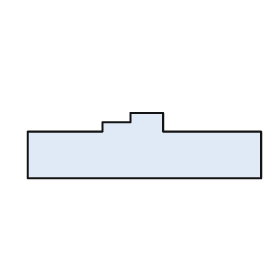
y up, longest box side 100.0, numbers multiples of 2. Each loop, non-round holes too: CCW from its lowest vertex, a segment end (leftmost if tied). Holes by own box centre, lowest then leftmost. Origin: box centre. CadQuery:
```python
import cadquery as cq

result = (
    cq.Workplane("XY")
    .moveTo(-50.0, -14.0)
    .lineTo(50.0, -14.0)
    .lineTo(50.0, 6.0)
    .lineTo(8.0, 6.0)
    .lineTo(8.0, 14.0)
    .lineTo(-6.0, 14.0)
    .lineTo(-6.0, 10.0)
    .lineTo(-18.0, 10.0)
    .lineTo(-18.0, 6.0)
    .lineTo(-50.0, 6.0)
    .close()
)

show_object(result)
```